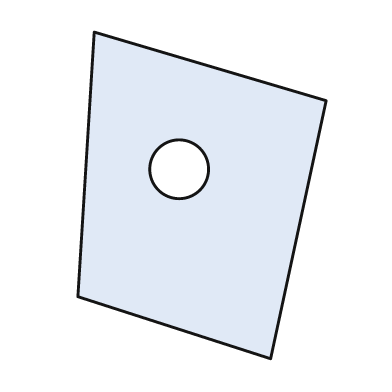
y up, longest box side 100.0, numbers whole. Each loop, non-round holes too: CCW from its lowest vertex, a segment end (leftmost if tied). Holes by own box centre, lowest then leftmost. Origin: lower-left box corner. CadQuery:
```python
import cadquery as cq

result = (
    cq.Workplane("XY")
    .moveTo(59.0, 0.0)
    .lineTo(76.0, 79.0)
    .lineTo(5.0, 100.0)
    .lineTo(0.0, 19.0)
    .close()
    .moveTo(31.0, 58.0)
    .circle(9.0)
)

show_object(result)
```